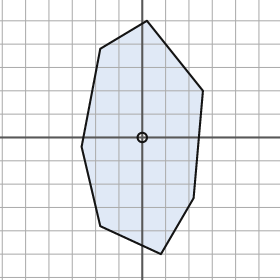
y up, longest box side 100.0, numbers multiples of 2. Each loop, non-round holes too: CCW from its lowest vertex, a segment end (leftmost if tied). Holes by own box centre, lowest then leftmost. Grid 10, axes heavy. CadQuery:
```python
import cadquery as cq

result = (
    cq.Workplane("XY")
    .moveTo(8.0, -50.0)
    .lineTo(22.0, -26.0)
    .lineTo(26.0, 20.0)
    .lineTo(2.0, 50.0)
    .lineTo(-18.0, 38.0)
    .lineTo(-26.0, -4.0)
    .lineTo(-18.0, -38.0)
    .close()
    .moveTo(0.0, 0.0)
    .circle(2.0)
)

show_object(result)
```